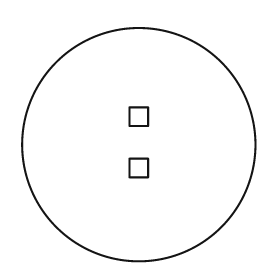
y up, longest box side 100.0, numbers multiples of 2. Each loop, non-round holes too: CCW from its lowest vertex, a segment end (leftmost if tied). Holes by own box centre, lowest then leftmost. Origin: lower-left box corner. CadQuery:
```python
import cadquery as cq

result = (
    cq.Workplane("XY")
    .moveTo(50.0, 50.0)
    .circle(50.0)
    .moveTo(46.0, 36.0)
    .lineTo(54.0, 36.0)
    .lineTo(54.0, 44.0)
    .lineTo(46.0, 44.0)
    .close()
    .moveTo(46.0, 58.0)
    .lineTo(54.0, 58.0)
    .lineTo(54.0, 66.0)
    .lineTo(46.0, 66.0)
    .close()
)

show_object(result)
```